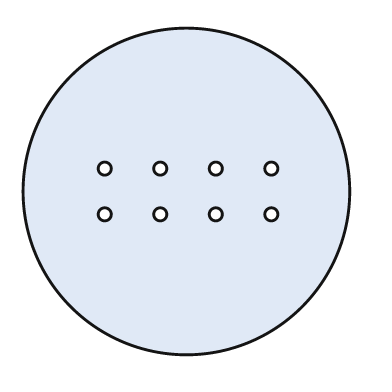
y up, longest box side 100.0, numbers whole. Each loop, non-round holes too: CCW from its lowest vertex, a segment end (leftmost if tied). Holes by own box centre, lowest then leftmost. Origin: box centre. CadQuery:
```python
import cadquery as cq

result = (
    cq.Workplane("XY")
    .moveTo(0.0, 0.0)
    .circle(50.0)
    .moveTo(-25.0, -7.0)
    .circle(2.0)
    .moveTo(-8.0, -7.0)
    .circle(2.0)
    .moveTo(9.0, -7.0)
    .circle(2.0)
    .moveTo(26.0, -7.0)
    .circle(2.0)
    .moveTo(-25.0, 7.0)
    .circle(2.0)
    .moveTo(-8.0, 7.0)
    .circle(2.0)
    .moveTo(9.0, 7.0)
    .circle(2.0)
    .moveTo(26.0, 7.0)
    .circle(2.0)
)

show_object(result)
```